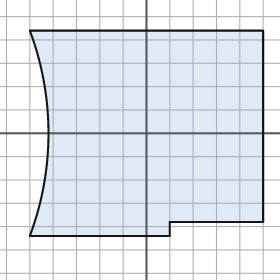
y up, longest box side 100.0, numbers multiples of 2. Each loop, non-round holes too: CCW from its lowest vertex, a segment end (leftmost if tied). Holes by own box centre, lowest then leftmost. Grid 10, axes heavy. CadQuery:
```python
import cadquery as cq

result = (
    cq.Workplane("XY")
    .moveTo(-50.0, -44.0)
    .lineTo(10.0, -44.0)
    .lineTo(10.0, -38.0)
    .lineTo(50.0, -38.0)
    .lineTo(50.0, 44.0)
    .lineTo(-50.0, 44.0)
    .threePointArc((-42.0, 0.0), (-50.0, -44.0))
    .close()
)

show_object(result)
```